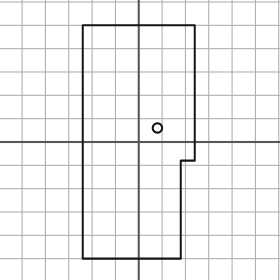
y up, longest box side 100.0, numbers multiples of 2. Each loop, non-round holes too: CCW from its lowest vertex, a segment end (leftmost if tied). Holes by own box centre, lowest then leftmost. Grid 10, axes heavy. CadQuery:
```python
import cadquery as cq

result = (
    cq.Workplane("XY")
    .moveTo(-24.0, -50.0)
    .lineTo(18.0, -50.0)
    .lineTo(18.0, -8.0)
    .lineTo(24.0, -8.0)
    .lineTo(24.0, 50.0)
    .lineTo(-24.0, 50.0)
    .close()
    .moveTo(8.0, 6.0)
    .circle(2.0)
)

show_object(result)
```